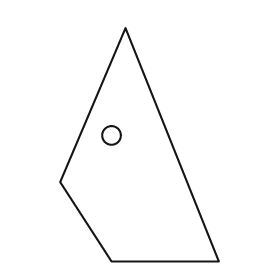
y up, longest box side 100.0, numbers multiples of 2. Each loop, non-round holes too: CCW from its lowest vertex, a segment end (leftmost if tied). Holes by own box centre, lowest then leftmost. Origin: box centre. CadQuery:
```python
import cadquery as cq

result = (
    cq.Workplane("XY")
    .moveTo(-12.0, -50.0)
    .lineTo(34.0, -50.0)
    .lineTo(-6.0, 50.0)
    .lineTo(-34.0, -16.0)
    .close()
    .moveTo(-12.0, 4.0)
    .circle(4.0)
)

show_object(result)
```